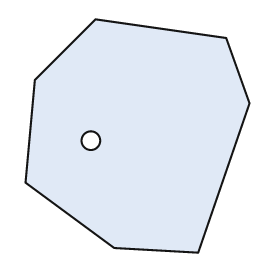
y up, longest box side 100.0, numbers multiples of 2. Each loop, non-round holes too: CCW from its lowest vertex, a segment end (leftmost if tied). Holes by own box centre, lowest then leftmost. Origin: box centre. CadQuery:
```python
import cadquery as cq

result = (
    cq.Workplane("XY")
    .moveTo(26.0, -50.0)
    .lineTo(48.0, 14.0)
    .lineTo(38.0, 42.0)
    .lineTo(-18.0, 50.0)
    .lineTo(-44.0, 24.0)
    .lineTo(-48.0, -20.0)
    .lineTo(-10.0, -48.0)
    .close()
    .moveTo(-20.0, -2.0)
    .circle(4.0)
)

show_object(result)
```